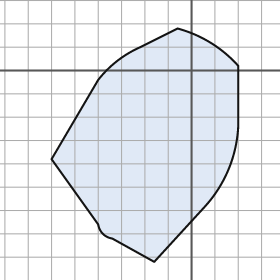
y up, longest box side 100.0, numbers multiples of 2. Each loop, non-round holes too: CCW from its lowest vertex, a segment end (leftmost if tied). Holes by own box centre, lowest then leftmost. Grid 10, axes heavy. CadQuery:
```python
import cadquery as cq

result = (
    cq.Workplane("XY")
    .moveTo(-16.0, -82.0)
    .lineTo(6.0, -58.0)
    .threePointArc((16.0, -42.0), (20.0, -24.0))
    .lineTo(20.0, 2.0)
    .threePointArc((8.0, 12.0), (-6.0, 18.0))
    .lineTo(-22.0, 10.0)
    .threePointArc((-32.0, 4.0), (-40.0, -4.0))
    .lineTo(-60.0, -38.0)
    .lineTo(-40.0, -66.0)
    .threePointArc((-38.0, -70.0), (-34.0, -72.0))
    .close()
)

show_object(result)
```